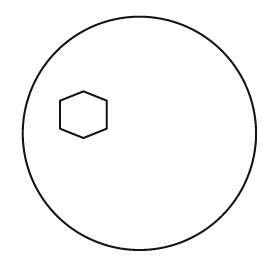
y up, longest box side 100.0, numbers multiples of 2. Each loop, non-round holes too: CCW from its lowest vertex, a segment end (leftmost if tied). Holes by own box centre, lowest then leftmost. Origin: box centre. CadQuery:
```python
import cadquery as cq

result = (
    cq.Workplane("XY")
    .moveTo(0.0, 0.0)
    .circle(50.0)
    .moveTo(-24.0, -2.0)
    .lineTo(-14.0, 2.0)
    .lineTo(-14.0, 14.0)
    .lineTo(-24.0, 18.0)
    .lineTo(-34.0, 14.0)
    .lineTo(-34.0, 2.0)
    .close()
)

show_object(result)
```